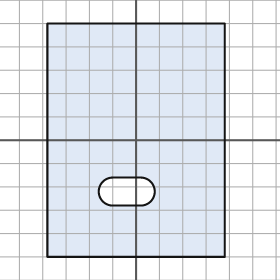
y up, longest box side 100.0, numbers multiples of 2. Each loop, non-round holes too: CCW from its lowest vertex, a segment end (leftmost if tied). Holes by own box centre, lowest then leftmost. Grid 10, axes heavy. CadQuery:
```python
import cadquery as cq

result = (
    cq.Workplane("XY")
    .moveTo(-38.0, -50.0)
    .lineTo(38.0, -50.0)
    .lineTo(38.0, 50.0)
    .lineTo(-38.0, 50.0)
    .close()
    .moveTo(-10.0, -28.0)
    .lineTo(2.0, -28.0)
    .threePointArc((8.0, -22.0), (2.0, -16.0))
    .lineTo(-10.0, -16.0)
    .threePointArc((-16.0, -22.0), (-10.0, -28.0))
    .close()
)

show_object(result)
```